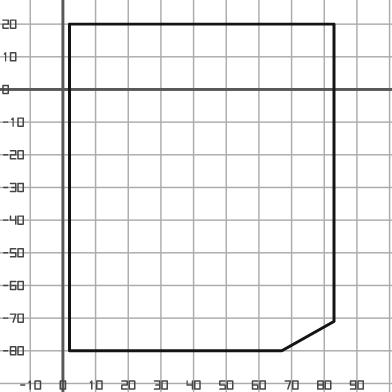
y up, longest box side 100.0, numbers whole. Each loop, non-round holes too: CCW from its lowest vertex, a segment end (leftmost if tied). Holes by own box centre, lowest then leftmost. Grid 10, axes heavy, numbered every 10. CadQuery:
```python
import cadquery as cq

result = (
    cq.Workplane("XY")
    .moveTo(2.0, -80.0)
    .lineTo(67.0, -80.0)
    .lineTo(83.0, -71.0)
    .lineTo(83.0, 20.0)
    .lineTo(2.0, 20.0)
    .close()
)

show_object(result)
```